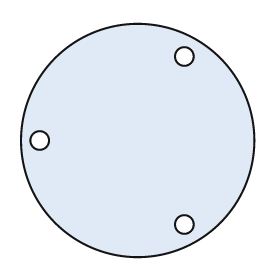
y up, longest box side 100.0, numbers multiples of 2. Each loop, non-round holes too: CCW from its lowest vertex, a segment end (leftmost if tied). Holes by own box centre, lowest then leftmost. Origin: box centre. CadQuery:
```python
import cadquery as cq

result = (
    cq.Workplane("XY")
    .moveTo(0.0, 0.0)
    .circle(50.0)
    .moveTo(20.0, -36.0)
    .circle(4.0)
    .moveTo(-42.0, 0.0)
    .circle(4.0)
    .moveTo(20.0, 36.0)
    .circle(4.0)
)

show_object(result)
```